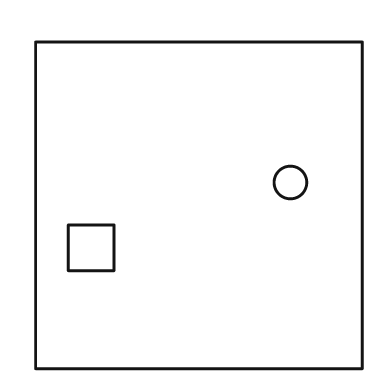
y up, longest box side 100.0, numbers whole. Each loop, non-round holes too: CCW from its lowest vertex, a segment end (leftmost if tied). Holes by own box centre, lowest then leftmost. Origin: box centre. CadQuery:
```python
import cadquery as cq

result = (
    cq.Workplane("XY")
    .moveTo(-50.0, -50.0)
    .lineTo(50.0, -50.0)
    .lineTo(50.0, 50.0)
    .lineTo(-50.0, 50.0)
    .close()
    .moveTo(-40.0, -20.0)
    .lineTo(-26.0, -20.0)
    .lineTo(-26.0, -6.0)
    .lineTo(-40.0, -6.0)
    .close()
    .moveTo(28.0, 7.0)
    .circle(5.0)
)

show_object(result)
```